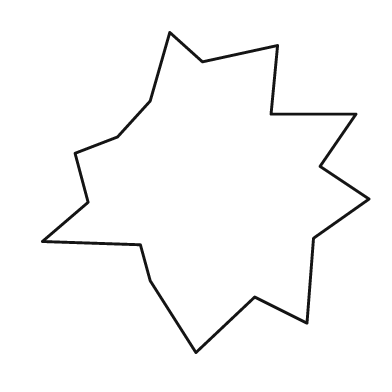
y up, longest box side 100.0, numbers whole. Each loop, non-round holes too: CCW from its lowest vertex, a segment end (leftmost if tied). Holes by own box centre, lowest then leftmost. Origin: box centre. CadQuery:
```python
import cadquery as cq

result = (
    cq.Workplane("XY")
    .moveTo(-3.0, -49.0)
    .lineTo(15.0, -32.0)
    .lineTo(31.0, -40.0)
    .lineTo(33.0, -14.0)
    .lineTo(50.0, -2.0)
    .lineTo(35.0, 8.0)
    .lineTo(46.0, 24.0)
    .lineTo(20.0, 24.0)
    .lineTo(22.0, 45.0)
    .lineTo(-1.0, 40.0)
    .lineTo(-11.0, 49.0)
    .lineTo(-17.0, 28.0)
    .lineTo(-27.0, 17.0)
    .lineTo(-40.0, 12.0)
    .lineTo(-36.0, -3.0)
    .lineTo(-50.0, -15.0)
    .lineTo(-20.0, -16.0)
    .lineTo(-17.0, -27.0)
    .close()
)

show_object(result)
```